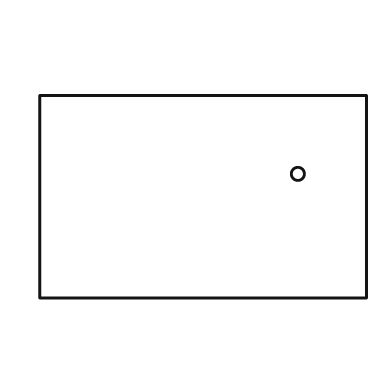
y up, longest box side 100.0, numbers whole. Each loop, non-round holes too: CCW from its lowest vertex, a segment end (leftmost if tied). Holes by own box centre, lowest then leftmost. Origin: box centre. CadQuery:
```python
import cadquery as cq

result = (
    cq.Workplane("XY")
    .moveTo(-50.0, -31.0)
    .lineTo(50.0, -31.0)
    .lineTo(50.0, 31.0)
    .lineTo(-50.0, 31.0)
    .close()
    .moveTo(29.0, 7.0)
    .circle(2.0)
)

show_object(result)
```